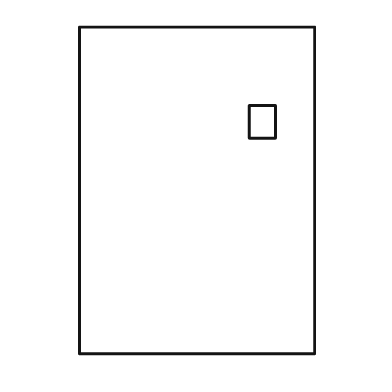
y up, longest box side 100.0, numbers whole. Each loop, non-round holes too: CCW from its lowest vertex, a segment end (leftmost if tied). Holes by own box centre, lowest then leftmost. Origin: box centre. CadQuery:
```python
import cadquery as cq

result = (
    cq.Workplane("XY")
    .moveTo(-36.0, -50.0)
    .lineTo(36.0, -50.0)
    .lineTo(36.0, 50.0)
    .lineTo(-36.0, 50.0)
    .close()
    .moveTo(16.0, 16.0)
    .lineTo(24.0, 16.0)
    .lineTo(24.0, 26.0)
    .lineTo(16.0, 26.0)
    .close()
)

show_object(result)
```